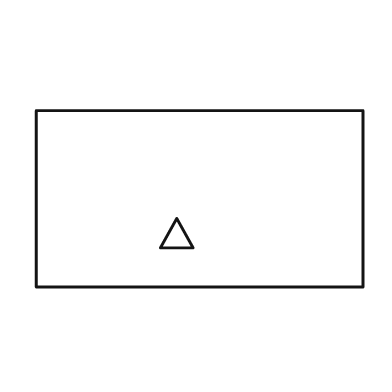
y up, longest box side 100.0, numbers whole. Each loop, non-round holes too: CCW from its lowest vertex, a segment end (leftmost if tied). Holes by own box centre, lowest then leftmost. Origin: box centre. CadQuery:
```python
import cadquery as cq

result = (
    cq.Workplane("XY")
    .moveTo(-50.0, -27.0)
    .lineTo(50.0, -27.0)
    .lineTo(50.0, 27.0)
    .lineTo(-50.0, 27.0)
    .close()
    .moveTo(-12.0, -15.0)
    .lineTo(-2.0, -15.0)
    .lineTo(-7.0, -6.0)
    .close()
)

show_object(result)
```